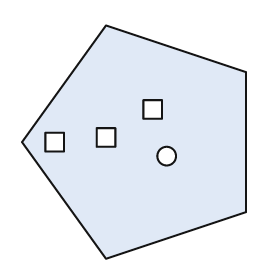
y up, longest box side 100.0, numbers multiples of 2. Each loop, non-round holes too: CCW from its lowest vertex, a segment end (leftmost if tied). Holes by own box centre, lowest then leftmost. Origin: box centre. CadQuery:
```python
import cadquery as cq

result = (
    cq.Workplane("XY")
    .moveTo(-12.0, -50.0)
    .lineTo(48.0, -30.0)
    .lineTo(48.0, 30.0)
    .lineTo(-12.0, 50.0)
    .lineTo(-48.0, 0.0)
    .close()
    .moveTo(14.0, -6.0)
    .circle(4.0)
    .moveTo(-38.0, -4.0)
    .lineTo(-30.0, -4.0)
    .lineTo(-30.0, 4.0)
    .lineTo(-38.0, 4.0)
    .close()
    .moveTo(-16.0, -2.0)
    .lineTo(-8.0, -2.0)
    .lineTo(-8.0, 6.0)
    .lineTo(-16.0, 6.0)
    .close()
    .moveTo(4.0, 10.0)
    .lineTo(12.0, 10.0)
    .lineTo(12.0, 18.0)
    .lineTo(4.0, 18.0)
    .close()
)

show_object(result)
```